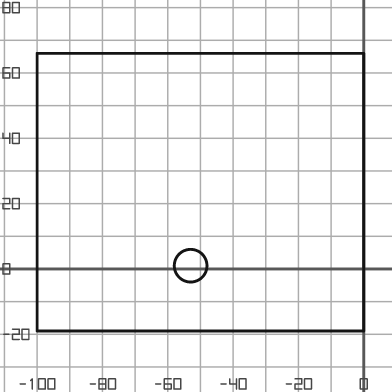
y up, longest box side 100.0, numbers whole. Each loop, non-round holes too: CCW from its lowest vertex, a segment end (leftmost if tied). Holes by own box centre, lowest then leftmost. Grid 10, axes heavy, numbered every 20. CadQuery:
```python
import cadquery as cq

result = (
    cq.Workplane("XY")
    .moveTo(-100.0, -19.0)
    .lineTo(0.0, -19.0)
    .lineTo(0.0, 66.0)
    .lineTo(-100.0, 66.0)
    .close()
    .moveTo(-53.0, 1.0)
    .circle(5.0)
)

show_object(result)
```